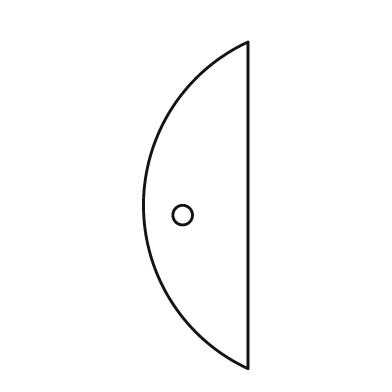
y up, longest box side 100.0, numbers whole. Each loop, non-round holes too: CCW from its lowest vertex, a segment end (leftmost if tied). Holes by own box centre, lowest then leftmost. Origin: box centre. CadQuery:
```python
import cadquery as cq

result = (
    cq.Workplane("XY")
    .moveTo(16.0, -50.0)
    .lineTo(16.0, 50.0)
    .threePointArc((-16.0, 0.0), (16.0, -50.0))
    .close()
    .moveTo(-4.0, -3.0)
    .circle(3.0)
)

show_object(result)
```